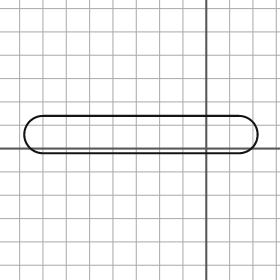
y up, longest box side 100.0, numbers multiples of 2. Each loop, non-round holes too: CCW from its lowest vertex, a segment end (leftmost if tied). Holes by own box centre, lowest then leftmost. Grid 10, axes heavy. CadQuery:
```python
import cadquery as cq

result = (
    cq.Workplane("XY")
    .moveTo(-70.0, -2.0)
    .lineTo(14.0, -2.0)
    .threePointArc((22.0, 6.0), (14.0, 14.0))
    .lineTo(-70.0, 14.0)
    .threePointArc((-78.0, 6.0), (-70.0, -2.0))
    .close()
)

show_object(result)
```